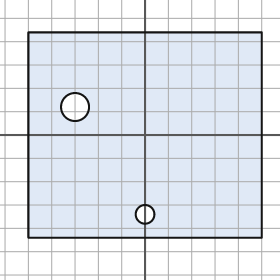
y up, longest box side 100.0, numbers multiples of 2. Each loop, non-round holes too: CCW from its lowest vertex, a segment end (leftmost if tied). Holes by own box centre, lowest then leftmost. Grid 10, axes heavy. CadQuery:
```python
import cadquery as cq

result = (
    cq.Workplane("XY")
    .moveTo(-50.0, -44.0)
    .lineTo(50.0, -44.0)
    .lineTo(50.0, 44.0)
    .lineTo(-50.0, 44.0)
    .close()
    .moveTo(0.0, -34.0)
    .circle(4.0)
    .moveTo(-30.0, 12.0)
    .circle(6.0)
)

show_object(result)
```